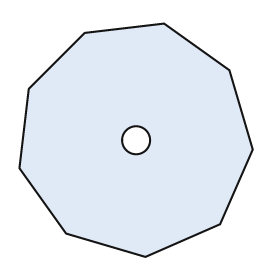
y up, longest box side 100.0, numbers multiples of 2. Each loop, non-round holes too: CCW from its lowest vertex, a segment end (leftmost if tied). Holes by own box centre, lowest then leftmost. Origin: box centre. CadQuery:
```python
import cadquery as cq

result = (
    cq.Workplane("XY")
    .moveTo(4.0, -50.0)
    .lineTo(36.0, -36.0)
    .lineTo(50.0, -4.0)
    .lineTo(40.0, 30.0)
    .lineTo(12.0, 50.0)
    .lineTo(-22.0, 46.0)
    .lineTo(-46.0, 22.0)
    .lineTo(-50.0, -12.0)
    .lineTo(-30.0, -40.0)
    .close()
    .moveTo(0.0, 0.0)
    .circle(6.0)
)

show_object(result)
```